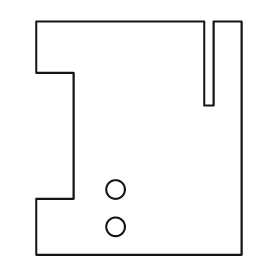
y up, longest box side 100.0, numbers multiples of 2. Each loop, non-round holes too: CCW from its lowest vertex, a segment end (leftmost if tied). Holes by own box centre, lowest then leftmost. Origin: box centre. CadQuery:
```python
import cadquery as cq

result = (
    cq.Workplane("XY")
    .moveTo(-44.0, -50.0)
    .lineTo(44.0, -50.0)
    .lineTo(44.0, 50.0)
    .lineTo(32.0, 50.0)
    .lineTo(32.0, 14.0)
    .lineTo(28.0, 14.0)
    .lineTo(28.0, 50.0)
    .lineTo(-44.0, 50.0)
    .lineTo(-44.0, 28.0)
    .lineTo(-28.0, 28.0)
    .lineTo(-28.0, -26.0)
    .lineTo(-44.0, -26.0)
    .close()
    .moveTo(-10.0, -38.0)
    .circle(4.0)
    .moveTo(-10.0, -22.0)
    .circle(4.0)
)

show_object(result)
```